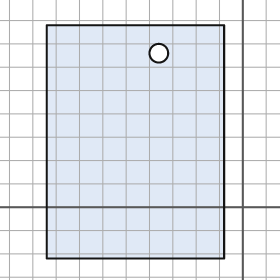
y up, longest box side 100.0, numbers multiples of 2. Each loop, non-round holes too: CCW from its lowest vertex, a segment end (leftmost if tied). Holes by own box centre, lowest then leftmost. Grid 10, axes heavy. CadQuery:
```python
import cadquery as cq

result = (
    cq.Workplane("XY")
    .moveTo(-84.0, -22.0)
    .lineTo(-8.0, -22.0)
    .lineTo(-8.0, 78.0)
    .lineTo(-84.0, 78.0)
    .close()
    .moveTo(-36.0, 66.0)
    .circle(4.0)
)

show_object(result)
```